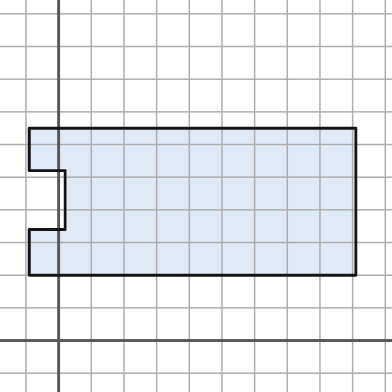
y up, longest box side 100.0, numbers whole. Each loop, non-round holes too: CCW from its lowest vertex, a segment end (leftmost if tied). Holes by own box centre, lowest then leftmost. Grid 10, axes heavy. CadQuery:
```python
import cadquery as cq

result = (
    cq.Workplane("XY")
    .moveTo(-9.0, 20.0)
    .lineTo(91.0, 20.0)
    .lineTo(91.0, 65.0)
    .lineTo(-9.0, 65.0)
    .lineTo(-9.0, 52.0)
    .lineTo(2.0, 52.0)
    .lineTo(2.0, 34.0)
    .lineTo(-9.0, 34.0)
    .close()
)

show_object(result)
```